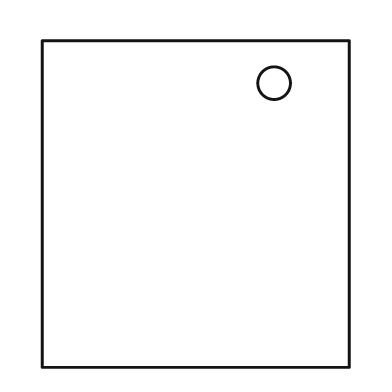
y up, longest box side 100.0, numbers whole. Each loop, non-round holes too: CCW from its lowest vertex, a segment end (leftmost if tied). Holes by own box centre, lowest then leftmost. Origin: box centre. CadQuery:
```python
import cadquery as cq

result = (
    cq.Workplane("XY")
    .moveTo(-47.0, -50.0)
    .lineTo(47.0, -50.0)
    .lineTo(47.0, 50.0)
    .lineTo(-47.0, 50.0)
    .close()
    .moveTo(24.0, 37.0)
    .circle(5.0)
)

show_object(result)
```